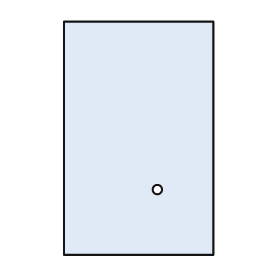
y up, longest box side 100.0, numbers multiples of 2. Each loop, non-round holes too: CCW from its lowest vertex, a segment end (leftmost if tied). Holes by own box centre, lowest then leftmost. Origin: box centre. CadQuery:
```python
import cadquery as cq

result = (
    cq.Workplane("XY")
    .moveTo(-32.0, -50.0)
    .lineTo(32.0, -50.0)
    .lineTo(32.0, 50.0)
    .lineTo(-32.0, 50.0)
    .close()
    .moveTo(8.0, -22.0)
    .circle(2.0)
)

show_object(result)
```